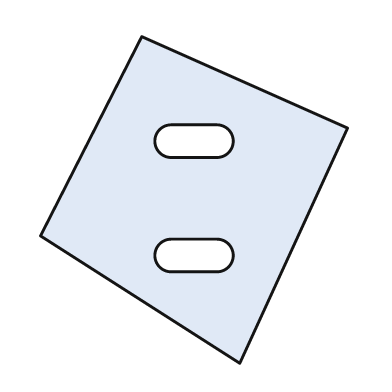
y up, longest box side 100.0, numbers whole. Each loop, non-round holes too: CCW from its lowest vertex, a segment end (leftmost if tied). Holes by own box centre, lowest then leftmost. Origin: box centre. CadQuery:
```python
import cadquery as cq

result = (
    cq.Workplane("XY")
    .moveTo(14.0, -50.0)
    .lineTo(47.0, 22.0)
    .lineTo(-16.0, 50.0)
    .lineTo(-47.0, -11.0)
    .close()
    .moveTo(-7.0, -22.0)
    .lineTo(7.0, -22.0)
    .threePointArc((12.0, -17.0), (7.0, -12.0))
    .lineTo(-7.0, -12.0)
    .threePointArc((-12.0, -17.0), (-7.0, -22.0))
    .close()
    .moveTo(-7.0, 13.0)
    .lineTo(7.0, 13.0)
    .threePointArc((12.0, 18.0), (7.0, 23.0))
    .lineTo(-7.0, 23.0)
    .threePointArc((-12.0, 18.0), (-7.0, 13.0))
    .close()
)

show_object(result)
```